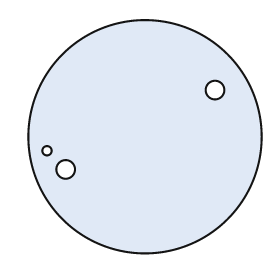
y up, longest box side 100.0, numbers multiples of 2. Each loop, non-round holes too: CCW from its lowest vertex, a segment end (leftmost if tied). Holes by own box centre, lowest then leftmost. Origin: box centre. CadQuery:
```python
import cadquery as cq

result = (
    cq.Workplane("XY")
    .moveTo(0.0, 0.0)
    .circle(50.0)
    .moveTo(-34.0, -14.0)
    .circle(4.0)
    .moveTo(-42.0, -6.0)
    .circle(2.0)
    .moveTo(30.0, 20.0)
    .circle(4.0)
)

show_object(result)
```